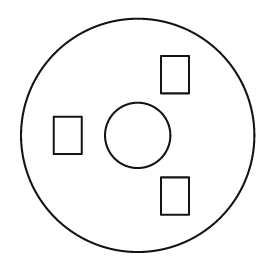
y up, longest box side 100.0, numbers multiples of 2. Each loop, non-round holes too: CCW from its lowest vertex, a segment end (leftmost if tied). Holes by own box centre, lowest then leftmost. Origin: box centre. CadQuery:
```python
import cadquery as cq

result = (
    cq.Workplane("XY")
    .moveTo(0.0, 0.0)
    .circle(50.0)
    .moveTo(10.0, -34.0)
    .lineTo(22.0, -34.0)
    .lineTo(22.0, -18.0)
    .lineTo(10.0, -18.0)
    .close()
    .moveTo(-36.0, -8.0)
    .lineTo(-24.0, -8.0)
    .lineTo(-24.0, 8.0)
    .lineTo(-36.0, 8.0)
    .close()
    .moveTo(0.0, 0.0)
    .circle(14.0)
    .moveTo(10.0, 18.0)
    .lineTo(22.0, 18.0)
    .lineTo(22.0, 34.0)
    .lineTo(10.0, 34.0)
    .close()
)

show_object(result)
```